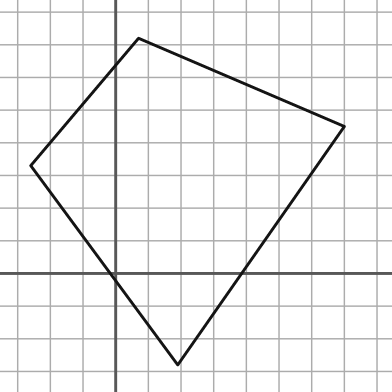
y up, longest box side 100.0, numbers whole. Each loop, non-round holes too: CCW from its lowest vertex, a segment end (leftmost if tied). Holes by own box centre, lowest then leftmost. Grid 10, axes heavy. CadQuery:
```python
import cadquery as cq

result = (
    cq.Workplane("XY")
    .moveTo(19.0, -28.0)
    .lineTo(70.0, 45.0)
    .lineTo(7.0, 72.0)
    .lineTo(-26.0, 33.0)
    .close()
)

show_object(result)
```